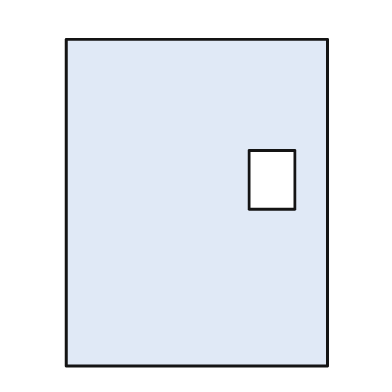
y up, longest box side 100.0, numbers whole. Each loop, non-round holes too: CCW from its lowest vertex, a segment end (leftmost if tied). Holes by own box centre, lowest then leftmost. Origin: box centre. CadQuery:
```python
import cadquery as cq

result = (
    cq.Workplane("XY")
    .moveTo(-40.0, -50.0)
    .lineTo(40.0, -50.0)
    .lineTo(40.0, 50.0)
    .lineTo(-40.0, 50.0)
    .close()
    .moveTo(16.0, -2.0)
    .lineTo(30.0, -2.0)
    .lineTo(30.0, 16.0)
    .lineTo(16.0, 16.0)
    .close()
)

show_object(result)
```